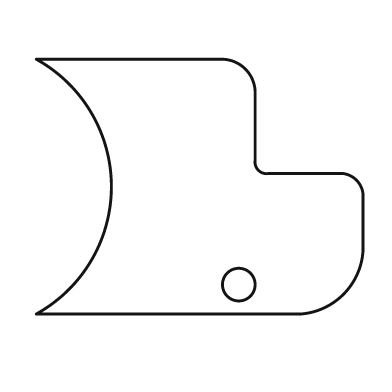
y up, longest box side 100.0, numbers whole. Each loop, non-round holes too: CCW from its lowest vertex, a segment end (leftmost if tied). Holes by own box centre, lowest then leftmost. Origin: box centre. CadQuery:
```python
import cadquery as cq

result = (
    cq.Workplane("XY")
    .moveTo(-50.0, -39.0)
    .lineTo(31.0, -39.0)
    .threePointArc((44.0, -33.0), (50.0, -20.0))
    .lineTo(50.0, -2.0)
    .threePointArc((48.0, 2.0), (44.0, 4.0))
    .lineTo(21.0, 4.0)
    .threePointArc((18.0, 5.0), (17.0, 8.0))
    .lineTo(17.0, 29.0)
    .threePointArc((14.0, 36.0), (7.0, 39.0))
    .lineTo(-50.0, 39.0)
    .threePointArc((-27.0, 0.0), (-50.0, -39.0))
    .close()
    .moveTo(12.0, -30.0)
    .circle(5.0)
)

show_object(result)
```